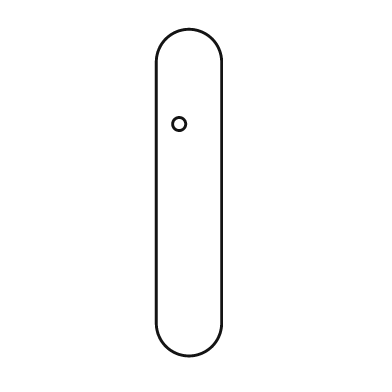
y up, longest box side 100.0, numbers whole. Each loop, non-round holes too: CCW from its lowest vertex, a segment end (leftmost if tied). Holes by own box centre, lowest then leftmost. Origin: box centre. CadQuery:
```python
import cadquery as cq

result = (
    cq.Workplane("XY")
    .moveTo(-10.0, -40.0)
    .threePointArc((0.0, -50.0), (10.0, -40.0))
    .lineTo(10.0, 40.0)
    .threePointArc((0.0, 50.0), (-10.0, 40.0))
    .close()
    .moveTo(-3.0, 21.0)
    .circle(2.0)
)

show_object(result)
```